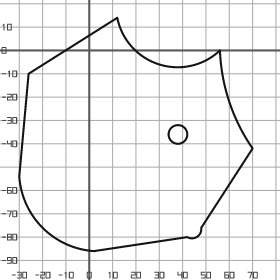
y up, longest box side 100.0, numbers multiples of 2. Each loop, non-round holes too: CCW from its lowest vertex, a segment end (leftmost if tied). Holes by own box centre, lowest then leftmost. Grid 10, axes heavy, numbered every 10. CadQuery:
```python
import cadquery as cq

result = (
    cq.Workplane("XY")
    .moveTo(2.0, -86.0)
    .lineTo(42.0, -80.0)
    .threePointArc((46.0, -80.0), (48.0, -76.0))
    .lineTo(70.0, -42.0)
    .threePointArc((60.0, -22.0), (56.0, 0.0))
    .threePointArc((30.0, -6.0), (12.0, 14.0))
    .lineTo(-26.0, -10.0)
    .lineTo(-30.0, -54.0)
    .threePointArc((-20.0, -76.0), (2.0, -86.0))
    .close()
    .moveTo(38.0, -36.0)
    .circle(4.0)
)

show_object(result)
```